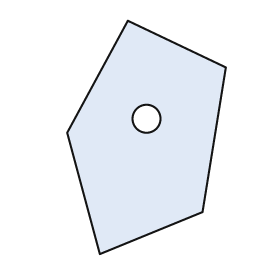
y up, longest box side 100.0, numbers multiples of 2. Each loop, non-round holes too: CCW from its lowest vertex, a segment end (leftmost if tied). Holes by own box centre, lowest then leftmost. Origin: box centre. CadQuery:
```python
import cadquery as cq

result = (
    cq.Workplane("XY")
    .moveTo(-20.0, -50.0)
    .lineTo(24.0, -32.0)
    .lineTo(34.0, 30.0)
    .lineTo(-8.0, 50.0)
    .lineTo(-34.0, 2.0)
    .close()
    .moveTo(0.0, 8.0)
    .circle(6.0)
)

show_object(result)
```